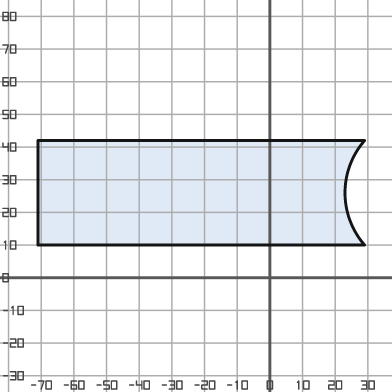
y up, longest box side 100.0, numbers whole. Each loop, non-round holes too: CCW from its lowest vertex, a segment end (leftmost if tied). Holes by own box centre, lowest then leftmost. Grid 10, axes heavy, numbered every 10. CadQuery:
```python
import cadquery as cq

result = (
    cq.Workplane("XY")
    .moveTo(-71.0, 10.0)
    .lineTo(29.0, 10.0)
    .threePointArc((23.0, 26.0), (29.0, 42.0))
    .lineTo(-71.0, 42.0)
    .close()
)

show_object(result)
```